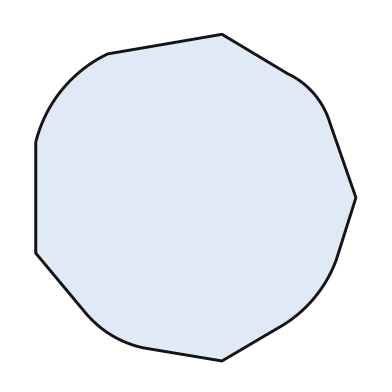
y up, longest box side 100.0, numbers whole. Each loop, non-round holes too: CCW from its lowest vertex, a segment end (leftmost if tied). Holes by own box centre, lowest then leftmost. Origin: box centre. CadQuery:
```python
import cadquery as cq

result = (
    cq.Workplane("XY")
    .moveTo(8.0, -50.0)
    .lineTo(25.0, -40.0)
    .threePointArc((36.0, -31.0), (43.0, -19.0))
    .lineTo(49.0, 0.0)
    .lineTo(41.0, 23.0)
    .threePointArc((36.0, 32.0), (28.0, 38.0))
    .lineTo(8.0, 50.0)
    .lineTo(-27.0, 44.0)
    .threePointArc((-41.0, 33.0), (-49.0, 17.0))
    .lineTo(-49.0, -17.0)
    .lineTo(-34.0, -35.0)
    .threePointArc((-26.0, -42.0), (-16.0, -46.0))
    .close()
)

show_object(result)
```